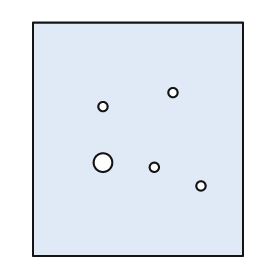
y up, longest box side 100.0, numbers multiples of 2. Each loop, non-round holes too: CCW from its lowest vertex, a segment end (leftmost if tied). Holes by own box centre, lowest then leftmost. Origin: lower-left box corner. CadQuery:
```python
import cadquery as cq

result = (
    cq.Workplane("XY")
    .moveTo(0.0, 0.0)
    .lineTo(90.0, 0.0)
    .lineTo(90.0, 100.0)
    .lineTo(0.0, 100.0)
    .close()
    .moveTo(72.0, 30.0)
    .circle(2.0)
    .moveTo(52.0, 38.0)
    .circle(2.0)
    .moveTo(30.0, 40.0)
    .circle(4.0)
    .moveTo(30.0, 64.0)
    .circle(2.0)
    .moveTo(60.0, 70.0)
    .circle(2.0)
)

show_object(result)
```